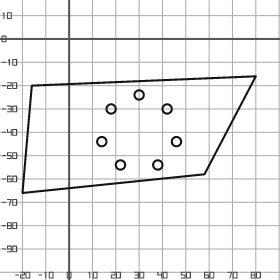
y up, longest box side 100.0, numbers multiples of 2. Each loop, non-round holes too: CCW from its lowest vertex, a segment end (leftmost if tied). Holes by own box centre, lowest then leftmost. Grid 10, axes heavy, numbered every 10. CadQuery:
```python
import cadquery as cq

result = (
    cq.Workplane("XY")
    .moveTo(-20.0, -66.0)
    .lineTo(58.0, -58.0)
    .lineTo(80.0, -16.0)
    .lineTo(-16.0, -20.0)
    .close()
    .moveTo(22.0, -54.0)
    .circle(2.0)
    .moveTo(38.0, -54.0)
    .circle(2.0)
    .moveTo(14.0, -44.0)
    .circle(2.0)
    .moveTo(46.0, -44.0)
    .circle(2.0)
    .moveTo(18.0, -30.0)
    .circle(2.0)
    .moveTo(42.0, -30.0)
    .circle(2.0)
    .moveTo(30.0, -24.0)
    .circle(2.0)
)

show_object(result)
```